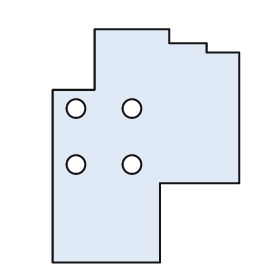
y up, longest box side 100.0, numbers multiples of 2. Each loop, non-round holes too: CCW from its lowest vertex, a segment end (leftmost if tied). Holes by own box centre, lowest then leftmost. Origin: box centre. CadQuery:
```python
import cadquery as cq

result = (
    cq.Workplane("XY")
    .moveTo(-40.0, -50.0)
    .lineTo(6.0, -50.0)
    .lineTo(6.0, -16.0)
    .lineTo(40.0, -16.0)
    .lineTo(40.0, 40.0)
    .lineTo(26.0, 40.0)
    .lineTo(26.0, 44.0)
    .lineTo(10.0, 44.0)
    .lineTo(10.0, 50.0)
    .lineTo(-22.0, 50.0)
    .lineTo(-22.0, 24.0)
    .lineTo(-40.0, 24.0)
    .close()
    .moveTo(-30.0, -8.0)
    .circle(4.0)
    .moveTo(-6.0, -8.0)
    .circle(4.0)
    .moveTo(-30.0, 16.0)
    .circle(4.0)
    .moveTo(-6.0, 16.0)
    .circle(4.0)
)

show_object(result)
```